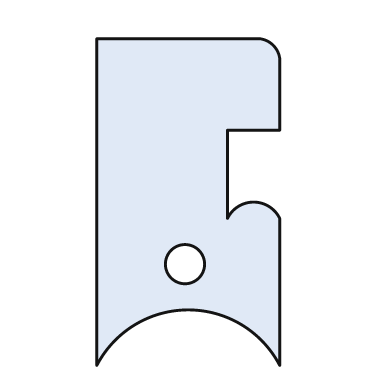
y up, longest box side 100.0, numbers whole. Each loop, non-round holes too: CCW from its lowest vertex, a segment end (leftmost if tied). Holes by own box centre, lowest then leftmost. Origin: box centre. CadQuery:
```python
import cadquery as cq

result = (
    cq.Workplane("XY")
    .moveTo(-28.0, -50.0)
    .threePointArc((0.0, -33.0), (28.0, -50.0))
    .lineTo(28.0, -5.0)
    .threePointArc((20.0, 0.0), (12.0, -5.0))
    .lineTo(12.0, 22.0)
    .lineTo(28.0, 22.0)
    .lineTo(28.0, 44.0)
    .threePointArc((26.0, 48.0), (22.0, 50.0))
    .lineTo(-28.0, 50.0)
    .close()
    .moveTo(-1.0, -19.0)
    .circle(6.0)
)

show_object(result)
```